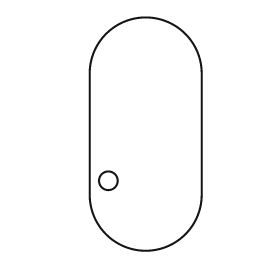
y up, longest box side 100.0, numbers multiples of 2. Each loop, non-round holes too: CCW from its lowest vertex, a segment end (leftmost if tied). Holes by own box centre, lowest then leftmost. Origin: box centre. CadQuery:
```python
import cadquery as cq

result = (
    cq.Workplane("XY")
    .moveTo(-24.0, -26.0)
    .threePointArc((0.0, -50.0), (24.0, -26.0))
    .lineTo(24.0, 26.0)
    .threePointArc((0.0, 50.0), (-24.0, 26.0))
    .close()
    .moveTo(-16.0, -20.0)
    .circle(4.0)
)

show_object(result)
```